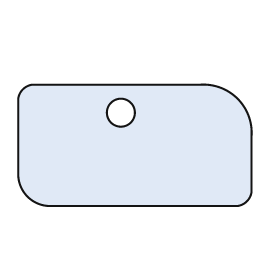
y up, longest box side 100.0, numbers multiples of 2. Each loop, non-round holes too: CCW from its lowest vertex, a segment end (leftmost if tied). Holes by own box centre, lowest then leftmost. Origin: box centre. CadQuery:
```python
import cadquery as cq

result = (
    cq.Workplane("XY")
    .moveTo(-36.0, -26.0)
    .lineTo(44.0, -26.0)
    .threePointArc((48.0, -24.0), (50.0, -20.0))
    .lineTo(50.0, 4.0)
    .threePointArc((44.0, 20.0), (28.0, 26.0))
    .lineTo(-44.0, 26.0)
    .threePointArc((-48.0, 24.0), (-50.0, 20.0))
    .lineTo(-50.0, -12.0)
    .threePointArc((-46.0, -22.0), (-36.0, -26.0))
    .close()
    .moveTo(-6.0, 14.0)
    .circle(6.0)
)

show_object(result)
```